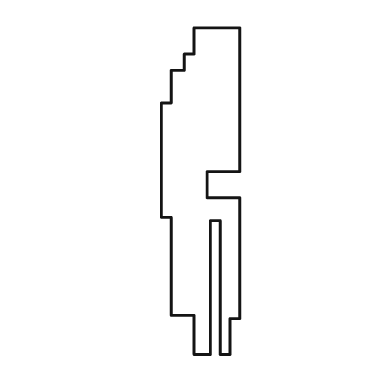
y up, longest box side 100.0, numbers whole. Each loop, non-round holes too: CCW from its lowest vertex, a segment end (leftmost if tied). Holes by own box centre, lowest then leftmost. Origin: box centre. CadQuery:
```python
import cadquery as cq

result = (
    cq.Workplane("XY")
    .moveTo(-2.0, -50.0)
    .lineTo(3.0, -50.0)
    .lineTo(3.0, -9.0)
    .lineTo(6.0, -9.0)
    .lineTo(6.0, -50.0)
    .lineTo(9.0, -50.0)
    .lineTo(9.0, -39.0)
    .lineTo(12.0, -39.0)
    .lineTo(12.0, -2.0)
    .lineTo(2.0, -2.0)
    .lineTo(2.0, 6.0)
    .lineTo(12.0, 6.0)
    .lineTo(12.0, 50.0)
    .lineTo(-2.0, 50.0)
    .lineTo(-2.0, 42.0)
    .lineTo(-5.0, 42.0)
    .lineTo(-5.0, 37.0)
    .lineTo(-9.0, 37.0)
    .lineTo(-9.0, 27.0)
    .lineTo(-12.0, 27.0)
    .lineTo(-12.0, -8.0)
    .lineTo(-9.0, -8.0)
    .lineTo(-9.0, -38.0)
    .lineTo(-2.0, -38.0)
    .close()
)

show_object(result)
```